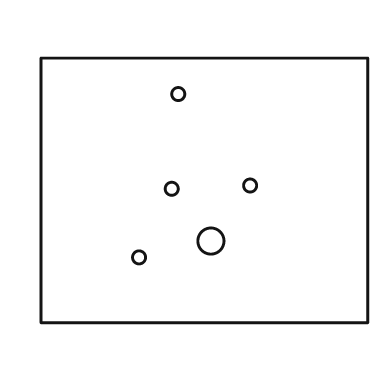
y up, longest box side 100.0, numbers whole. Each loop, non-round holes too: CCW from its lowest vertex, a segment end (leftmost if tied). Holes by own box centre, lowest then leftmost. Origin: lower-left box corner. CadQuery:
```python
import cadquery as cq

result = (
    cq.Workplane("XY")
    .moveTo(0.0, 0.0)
    .lineTo(100.0, 0.0)
    .lineTo(100.0, 81.0)
    .lineTo(0.0, 81.0)
    .close()
    .moveTo(30.0, 20.0)
    .circle(2.0)
    .moveTo(52.0, 25.0)
    .circle(4.0)
    .moveTo(40.0, 41.0)
    .circle(2.0)
    .moveTo(64.0, 42.0)
    .circle(2.0)
    .moveTo(42.0, 70.0)
    .circle(2.0)
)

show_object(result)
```